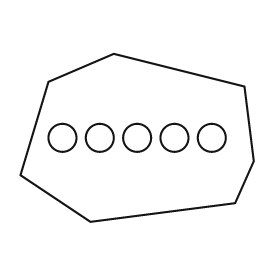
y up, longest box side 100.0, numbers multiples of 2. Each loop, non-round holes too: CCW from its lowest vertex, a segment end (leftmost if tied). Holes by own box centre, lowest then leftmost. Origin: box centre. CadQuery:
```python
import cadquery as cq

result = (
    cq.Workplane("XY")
    .moveTo(-20.0, -36.0)
    .lineTo(42.0, -28.0)
    .lineTo(50.0, -10.0)
    .lineTo(46.0, 22.0)
    .lineTo(-10.0, 36.0)
    .lineTo(-38.0, 24.0)
    .lineTo(-50.0, -16.0)
    .close()
    .moveTo(-32.0, 0.0)
    .circle(6.0)
    .moveTo(-16.0, 0.0)
    .circle(6.0)
    .moveTo(0.0, 0.0)
    .circle(6.0)
    .moveTo(16.0, 0.0)
    .circle(6.0)
    .moveTo(32.0, 0.0)
    .circle(6.0)
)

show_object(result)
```